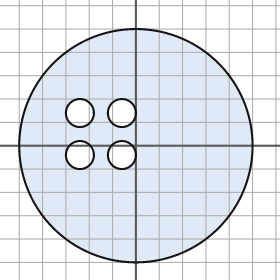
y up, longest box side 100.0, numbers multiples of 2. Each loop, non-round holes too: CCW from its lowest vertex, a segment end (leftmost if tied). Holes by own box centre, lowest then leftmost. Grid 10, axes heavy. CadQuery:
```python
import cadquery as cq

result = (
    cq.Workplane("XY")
    .moveTo(0.0, 0.0)
    .circle(50.0)
    .moveTo(-24.0, -4.0)
    .circle(6.0)
    .moveTo(-6.0, -4.0)
    .circle(6.0)
    .moveTo(-24.0, 14.0)
    .circle(6.0)
    .moveTo(-6.0, 14.0)
    .circle(6.0)
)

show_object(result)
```